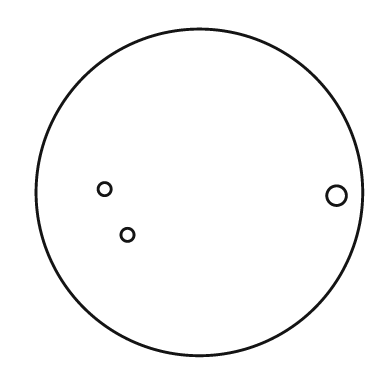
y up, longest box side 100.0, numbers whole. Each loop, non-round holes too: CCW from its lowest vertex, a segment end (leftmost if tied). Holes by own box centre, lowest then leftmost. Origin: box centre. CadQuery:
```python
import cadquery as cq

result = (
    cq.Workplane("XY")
    .moveTo(0.0, 0.0)
    .circle(50.0)
    .moveTo(-22.0, -13.0)
    .circle(2.0)
    .moveTo(42.0, -1.0)
    .circle(3.0)
    .moveTo(-29.0, 1.0)
    .circle(2.0)
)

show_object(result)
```